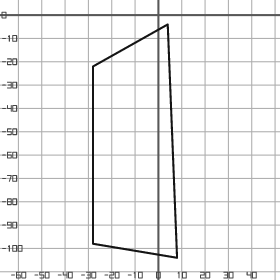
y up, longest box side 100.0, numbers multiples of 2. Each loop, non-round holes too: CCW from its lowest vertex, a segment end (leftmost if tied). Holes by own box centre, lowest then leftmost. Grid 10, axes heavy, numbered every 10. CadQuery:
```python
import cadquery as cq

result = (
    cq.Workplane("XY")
    .moveTo(8.0, -104.0)
    .lineTo(4.0, -4.0)
    .lineTo(-28.0, -22.0)
    .lineTo(-28.0, -98.0)
    .close()
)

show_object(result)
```